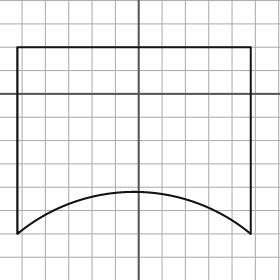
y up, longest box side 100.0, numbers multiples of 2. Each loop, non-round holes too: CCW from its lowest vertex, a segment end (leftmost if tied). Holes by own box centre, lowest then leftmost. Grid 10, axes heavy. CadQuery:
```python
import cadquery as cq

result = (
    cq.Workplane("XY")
    .moveTo(-52.0, -60.0)
    .threePointArc((-2.0, -42.0), (48.0, -60.0))
    .lineTo(48.0, 20.0)
    .lineTo(-52.0, 20.0)
    .close()
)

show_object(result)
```